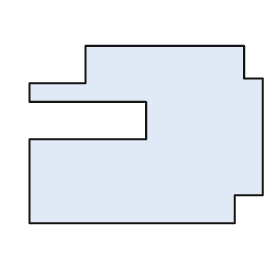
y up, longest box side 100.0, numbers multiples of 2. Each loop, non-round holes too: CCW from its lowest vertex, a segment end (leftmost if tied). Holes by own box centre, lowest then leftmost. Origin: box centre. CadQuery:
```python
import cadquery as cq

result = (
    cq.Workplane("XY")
    .moveTo(-50.0, -38.0)
    .lineTo(38.0, -38.0)
    .lineTo(38.0, -26.0)
    .lineTo(50.0, -26.0)
    .lineTo(50.0, 24.0)
    .lineTo(42.0, 24.0)
    .lineTo(42.0, 38.0)
    .lineTo(-26.0, 38.0)
    .lineTo(-26.0, 22.0)
    .lineTo(-50.0, 22.0)
    .lineTo(-50.0, 14.0)
    .lineTo(0.0, 14.0)
    .lineTo(0.0, -2.0)
    .lineTo(-50.0, -2.0)
    .close()
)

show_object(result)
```